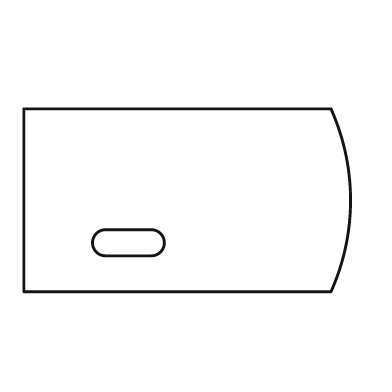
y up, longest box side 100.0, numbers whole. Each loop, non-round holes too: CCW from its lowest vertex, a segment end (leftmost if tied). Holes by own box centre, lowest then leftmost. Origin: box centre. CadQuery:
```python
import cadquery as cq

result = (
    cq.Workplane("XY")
    .moveTo(-50.0, -28.0)
    .lineTo(44.0, -28.0)
    .threePointArc((50.0, 0.0), (44.0, 28.0))
    .lineTo(-50.0, 28.0)
    .close()
    .moveTo(-25.0, -17.0)
    .lineTo(-11.0, -17.0)
    .threePointArc((-7.0, -13.0), (-11.0, -9.0))
    .lineTo(-25.0, -9.0)
    .threePointArc((-29.0, -13.0), (-25.0, -17.0))
    .close()
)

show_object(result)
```